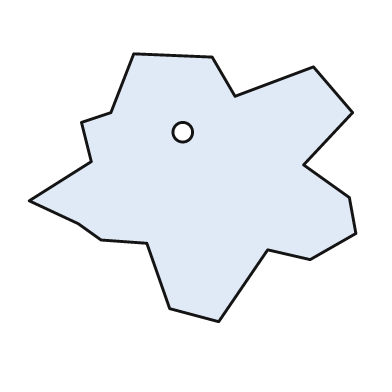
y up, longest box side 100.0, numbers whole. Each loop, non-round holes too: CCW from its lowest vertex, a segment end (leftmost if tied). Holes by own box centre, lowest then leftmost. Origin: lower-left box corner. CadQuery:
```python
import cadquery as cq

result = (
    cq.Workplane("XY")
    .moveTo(58.0, 0.0)
    .lineTo(73.0, 22.0)
    .lineTo(86.0, 19.0)
    .lineTo(100.0, 27.0)
    .lineTo(98.0, 38.0)
    .lineTo(84.0, 48.0)
    .lineTo(99.0, 64.0)
    .lineTo(87.0, 78.0)
    .lineTo(63.0, 69.0)
    .lineTo(56.0, 81.0)
    .lineTo(32.0, 82.0)
    .lineTo(25.0, 64.0)
    .lineTo(16.0, 61.0)
    .lineTo(19.0, 49.0)
    .lineTo(0.0, 37.0)
    .lineTo(15.0, 30.0)
    .lineTo(22.0, 25.0)
    .lineTo(36.0, 24.0)
    .lineTo(43.0, 4.0)
    .close()
    .moveTo(47.0, 58.0)
    .circle(3.0)
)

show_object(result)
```